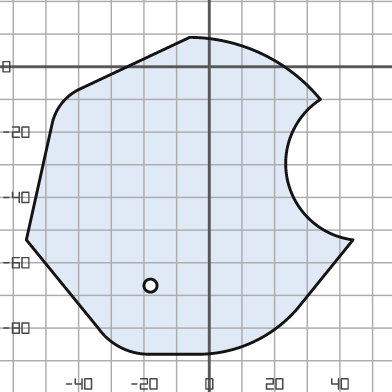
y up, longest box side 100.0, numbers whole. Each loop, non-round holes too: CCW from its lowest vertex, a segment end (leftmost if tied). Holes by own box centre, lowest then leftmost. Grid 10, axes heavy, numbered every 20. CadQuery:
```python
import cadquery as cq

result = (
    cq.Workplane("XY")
    .moveTo(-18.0, -88.0)
    .lineTo(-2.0, -88.0)
    .threePointArc((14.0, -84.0), (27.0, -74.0))
    .lineTo(44.0, -53.0)
    .threePointArc((24.0, -35.0), (34.0, -10.0))
    .threePointArc((16.0, 4.0), (-6.0, 9.0))
    .lineTo(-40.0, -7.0)
    .threePointArc((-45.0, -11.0), (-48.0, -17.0))
    .lineTo(-56.0, -53.0)
    .lineTo(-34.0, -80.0)
    .threePointArc((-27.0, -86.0), (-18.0, -88.0))
    .close()
    .moveTo(-18.0, -67.0)
    .circle(2.0)
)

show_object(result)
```